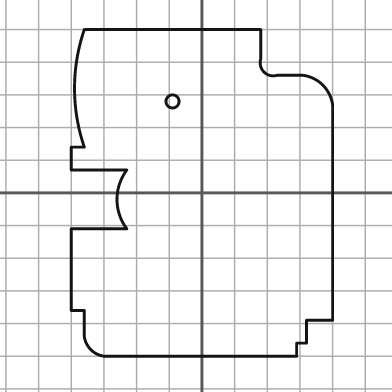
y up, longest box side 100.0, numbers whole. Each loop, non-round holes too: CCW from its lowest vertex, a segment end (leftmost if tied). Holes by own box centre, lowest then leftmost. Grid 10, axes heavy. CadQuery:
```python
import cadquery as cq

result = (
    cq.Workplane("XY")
    .moveTo(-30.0, -50.0)
    .lineTo(29.0, -50.0)
    .lineTo(29.0, -46.0)
    .lineTo(32.0, -46.0)
    .lineTo(32.0, -39.0)
    .lineTo(40.0, -39.0)
    .lineTo(40.0, 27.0)
    .threePointArc((37.0, 33.0), (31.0, 36.0))
    .lineTo(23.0, 36.0)
    .threePointArc((19.0, 37.0), (18.0, 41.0))
    .lineTo(18.0, 50.0)
    .lineTo(-36.0, 50.0)
    .threePointArc((-39.0, 32.0), (-36.0, 14.0))
    .lineTo(-40.0, 14.0)
    .lineTo(-40.0, 7.0)
    .lineTo(-23.0, 7.0)
    .threePointArc((-26.0, -2.0), (-23.0, -11.0))
    .lineTo(-40.0, -11.0)
    .lineTo(-40.0, -36.0)
    .lineTo(-36.0, -36.0)
    .lineTo(-36.0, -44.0)
    .threePointArc((-34.0, -48.0), (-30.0, -50.0))
    .close()
    .moveTo(-9.0, 28.0)
    .circle(2.0)
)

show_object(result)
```